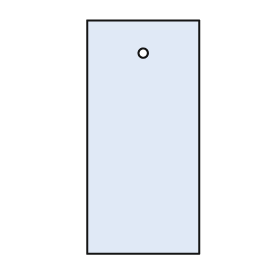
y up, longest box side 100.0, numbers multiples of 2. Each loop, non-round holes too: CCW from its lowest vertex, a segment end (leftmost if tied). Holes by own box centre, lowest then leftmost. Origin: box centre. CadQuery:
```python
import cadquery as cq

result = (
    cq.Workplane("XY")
    .moveTo(-24.0, -50.0)
    .lineTo(24.0, -50.0)
    .lineTo(24.0, 50.0)
    .lineTo(-24.0, 50.0)
    .close()
    .moveTo(0.0, 36.0)
    .circle(2.0)
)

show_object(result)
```